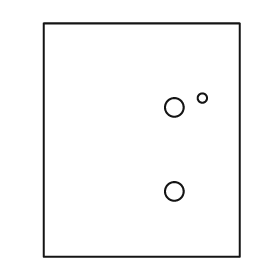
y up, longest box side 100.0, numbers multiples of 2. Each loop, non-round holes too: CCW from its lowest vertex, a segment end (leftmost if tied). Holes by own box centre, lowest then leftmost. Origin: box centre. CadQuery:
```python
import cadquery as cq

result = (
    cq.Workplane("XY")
    .moveTo(-42.0, -50.0)
    .lineTo(42.0, -50.0)
    .lineTo(42.0, 50.0)
    .lineTo(-42.0, 50.0)
    .close()
    .moveTo(14.0, -22.0)
    .circle(4.0)
    .moveTo(14.0, 14.0)
    .circle(4.0)
    .moveTo(26.0, 18.0)
    .circle(2.0)
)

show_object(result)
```